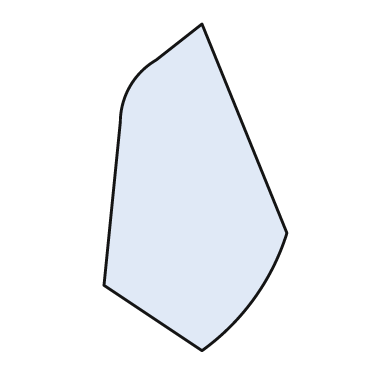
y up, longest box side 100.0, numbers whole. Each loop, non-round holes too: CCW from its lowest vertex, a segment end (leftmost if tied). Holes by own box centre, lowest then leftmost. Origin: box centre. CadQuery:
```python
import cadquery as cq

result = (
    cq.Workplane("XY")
    .moveTo(2.0, -50.0)
    .threePointArc((18.0, -34.0), (28.0, -14.0))
    .lineTo(2.0, 50.0)
    .lineTo(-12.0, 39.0)
    .threePointArc((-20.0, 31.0), (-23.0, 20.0))
    .lineTo(-28.0, -30.0)
    .close()
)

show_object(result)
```